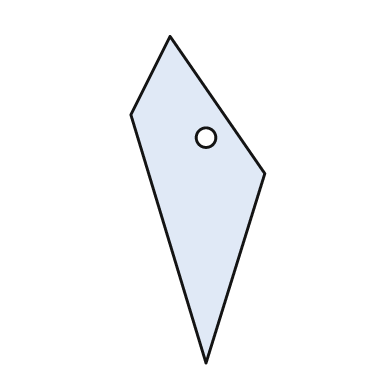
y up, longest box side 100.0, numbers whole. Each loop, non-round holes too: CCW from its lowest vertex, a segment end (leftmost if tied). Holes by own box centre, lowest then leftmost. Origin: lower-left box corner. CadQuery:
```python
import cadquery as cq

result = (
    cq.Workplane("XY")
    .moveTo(23.0, 0.0)
    .lineTo(41.0, 58.0)
    .lineTo(12.0, 100.0)
    .lineTo(0.0, 76.0)
    .close()
    .moveTo(23.0, 69.0)
    .circle(3.0)
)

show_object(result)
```